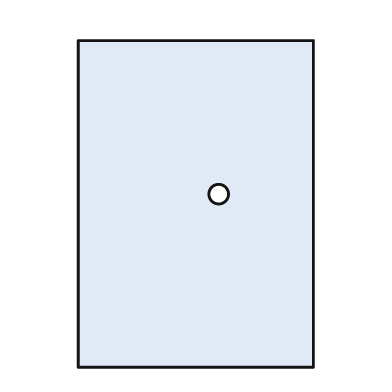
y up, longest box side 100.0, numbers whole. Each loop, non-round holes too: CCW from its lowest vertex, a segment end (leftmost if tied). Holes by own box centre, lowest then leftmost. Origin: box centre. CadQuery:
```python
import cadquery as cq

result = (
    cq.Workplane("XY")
    .moveTo(-36.0, -50.0)
    .lineTo(36.0, -50.0)
    .lineTo(36.0, 50.0)
    .lineTo(-36.0, 50.0)
    .close()
    .moveTo(7.0, 3.0)
    .circle(3.0)
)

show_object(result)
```